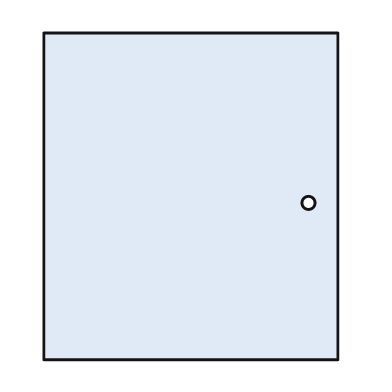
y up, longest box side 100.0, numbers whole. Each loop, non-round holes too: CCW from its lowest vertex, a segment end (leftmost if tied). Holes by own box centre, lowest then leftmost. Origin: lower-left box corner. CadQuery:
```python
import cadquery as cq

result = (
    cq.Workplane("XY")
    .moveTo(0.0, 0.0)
    .lineTo(90.0, 0.0)
    .lineTo(90.0, 100.0)
    .lineTo(0.0, 100.0)
    .close()
    .moveTo(81.0, 48.0)
    .circle(2.0)
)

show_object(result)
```